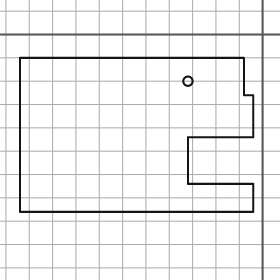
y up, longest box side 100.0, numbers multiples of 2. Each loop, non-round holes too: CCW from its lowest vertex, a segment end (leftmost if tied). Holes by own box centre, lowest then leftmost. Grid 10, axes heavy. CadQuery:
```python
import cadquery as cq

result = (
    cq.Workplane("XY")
    .moveTo(-104.0, -76.0)
    .lineTo(-4.0, -76.0)
    .lineTo(-4.0, -64.0)
    .lineTo(-32.0, -64.0)
    .lineTo(-32.0, -44.0)
    .lineTo(-4.0, -44.0)
    .lineTo(-4.0, -26.0)
    .lineTo(-8.0, -26.0)
    .lineTo(-8.0, -10.0)
    .lineTo(-104.0, -10.0)
    .close()
    .moveTo(-32.0, -20.0)
    .circle(2.0)
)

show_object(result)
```